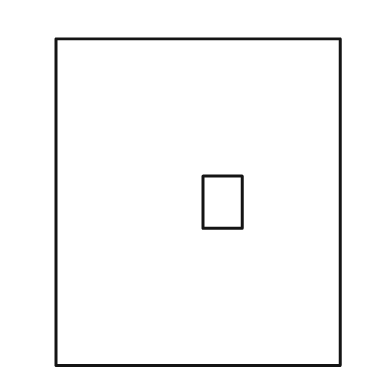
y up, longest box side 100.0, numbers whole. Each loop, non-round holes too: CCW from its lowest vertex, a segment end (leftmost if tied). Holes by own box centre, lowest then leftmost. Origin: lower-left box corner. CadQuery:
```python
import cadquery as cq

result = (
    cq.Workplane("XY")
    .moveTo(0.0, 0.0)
    .lineTo(87.0, 0.0)
    .lineTo(87.0, 100.0)
    .lineTo(0.0, 100.0)
    .close()
    .moveTo(45.0, 42.0)
    .lineTo(57.0, 42.0)
    .lineTo(57.0, 58.0)
    .lineTo(45.0, 58.0)
    .close()
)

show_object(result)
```